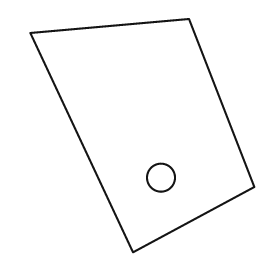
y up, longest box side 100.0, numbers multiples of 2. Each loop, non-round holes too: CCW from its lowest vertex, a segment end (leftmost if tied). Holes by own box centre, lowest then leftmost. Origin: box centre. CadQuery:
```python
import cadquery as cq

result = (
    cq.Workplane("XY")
    .moveTo(-4.0, -50.0)
    .lineTo(48.0, -22.0)
    .lineTo(20.0, 50.0)
    .lineTo(-48.0, 44.0)
    .close()
    .moveTo(8.0, -18.0)
    .circle(6.0)
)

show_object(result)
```